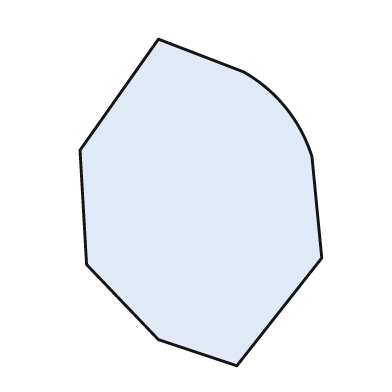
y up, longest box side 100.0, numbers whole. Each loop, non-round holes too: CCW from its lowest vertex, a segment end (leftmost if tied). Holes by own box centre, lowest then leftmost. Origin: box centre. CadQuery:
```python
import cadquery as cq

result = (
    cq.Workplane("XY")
    .moveTo(11.0, -50.0)
    .lineTo(37.0, -17.0)
    .lineTo(34.0, 14.0)
    .threePointArc((26.0, 29.0), (13.0, 40.0))
    .lineTo(-13.0, 50.0)
    .lineTo(-37.0, 16.0)
    .lineTo(-35.0, -19.0)
    .lineTo(-13.0, -42.0)
    .close()
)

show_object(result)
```